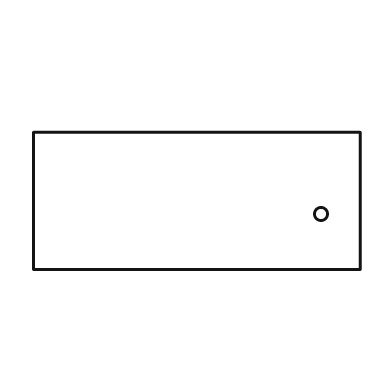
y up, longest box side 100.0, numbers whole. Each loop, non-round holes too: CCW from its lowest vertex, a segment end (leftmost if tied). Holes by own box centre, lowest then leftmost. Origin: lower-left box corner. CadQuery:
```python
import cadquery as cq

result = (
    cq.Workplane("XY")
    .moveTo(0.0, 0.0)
    .lineTo(100.0, 0.0)
    .lineTo(100.0, 42.0)
    .lineTo(0.0, 42.0)
    .close()
    .moveTo(88.0, 17.0)
    .circle(2.0)
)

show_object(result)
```